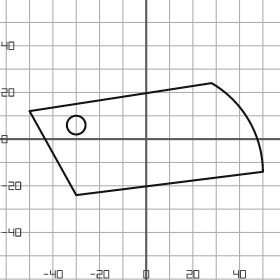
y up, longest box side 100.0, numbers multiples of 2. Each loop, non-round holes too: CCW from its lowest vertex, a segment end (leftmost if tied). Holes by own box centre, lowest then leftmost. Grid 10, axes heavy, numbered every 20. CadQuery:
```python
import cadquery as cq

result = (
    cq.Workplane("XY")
    .moveTo(-30.0, -24.0)
    .lineTo(50.0, -14.0)
    .threePointArc((44.0, 8.0), (28.0, 24.0))
    .lineTo(-50.0, 12.0)
    .close()
    .moveTo(-30.0, 6.0)
    .circle(4.0)
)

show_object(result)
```